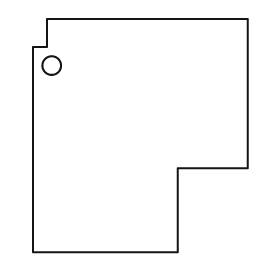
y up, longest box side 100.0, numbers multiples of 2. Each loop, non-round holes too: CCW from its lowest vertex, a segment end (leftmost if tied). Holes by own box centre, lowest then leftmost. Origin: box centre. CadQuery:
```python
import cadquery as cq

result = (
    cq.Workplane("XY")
    .moveTo(-46.0, -50.0)
    .lineTo(16.0, -50.0)
    .lineTo(16.0, -14.0)
    .lineTo(46.0, -14.0)
    .lineTo(46.0, 50.0)
    .lineTo(-40.0, 50.0)
    .lineTo(-40.0, 38.0)
    .lineTo(-46.0, 38.0)
    .close()
    .moveTo(-38.0, 30.0)
    .circle(4.0)
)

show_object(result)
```